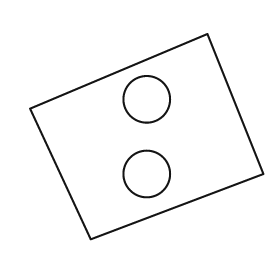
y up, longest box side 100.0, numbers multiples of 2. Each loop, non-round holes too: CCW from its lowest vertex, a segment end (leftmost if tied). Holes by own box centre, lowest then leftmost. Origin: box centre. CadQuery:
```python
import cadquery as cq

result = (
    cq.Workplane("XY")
    .moveTo(-24.0, -44.0)
    .lineTo(50.0, -16.0)
    .lineTo(26.0, 44.0)
    .lineTo(-50.0, 12.0)
    .close()
    .moveTo(0.0, -16.0)
    .circle(10.0)
    .moveTo(0.0, 16.0)
    .circle(10.0)
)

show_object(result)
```